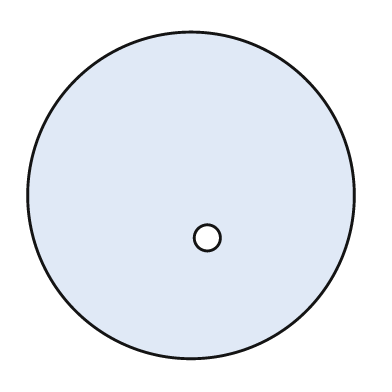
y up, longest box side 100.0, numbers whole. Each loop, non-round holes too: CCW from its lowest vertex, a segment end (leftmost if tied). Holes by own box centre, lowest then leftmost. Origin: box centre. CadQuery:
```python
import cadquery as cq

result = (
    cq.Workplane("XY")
    .moveTo(0.0, 0.0)
    .circle(50.0)
    .moveTo(5.0, -13.0)
    .circle(4.0)
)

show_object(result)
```